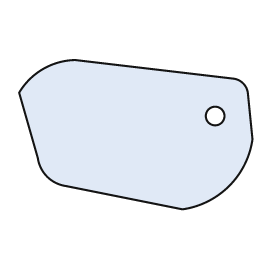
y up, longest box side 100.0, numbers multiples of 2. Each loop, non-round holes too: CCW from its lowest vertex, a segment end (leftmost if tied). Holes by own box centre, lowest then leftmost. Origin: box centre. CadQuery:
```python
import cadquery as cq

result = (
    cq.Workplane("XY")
    .moveTo(20.0, -32.0)
    .threePointArc((40.0, -22.0), (50.0, -2.0))
    .lineTo(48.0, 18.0)
    .threePointArc((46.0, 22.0), (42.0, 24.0))
    .lineTo(-26.0, 32.0)
    .threePointArc((-40.0, 28.0), (-50.0, 18.0))
    .lineTo(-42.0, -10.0)
    .threePointArc((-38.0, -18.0), (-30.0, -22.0))
    .close()
    .moveTo(34.0, 8.0)
    .circle(4.0)
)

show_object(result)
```